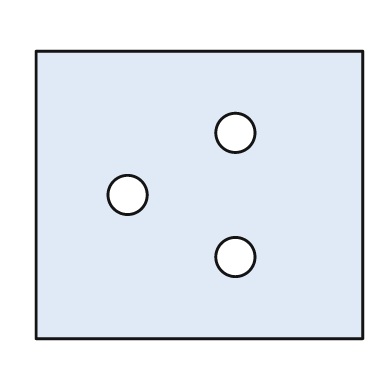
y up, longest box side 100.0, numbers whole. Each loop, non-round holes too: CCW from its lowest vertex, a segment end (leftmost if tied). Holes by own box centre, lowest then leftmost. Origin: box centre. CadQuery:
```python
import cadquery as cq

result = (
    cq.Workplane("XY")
    .moveTo(-50.0, -44.0)
    .lineTo(50.0, -44.0)
    .lineTo(50.0, 44.0)
    .lineTo(-50.0, 44.0)
    .close()
    .moveTo(11.0, -19.0)
    .circle(6.0)
    .moveTo(-22.0, 0.0)
    .circle(6.0)
    .moveTo(11.0, 19.0)
    .circle(6.0)
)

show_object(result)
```